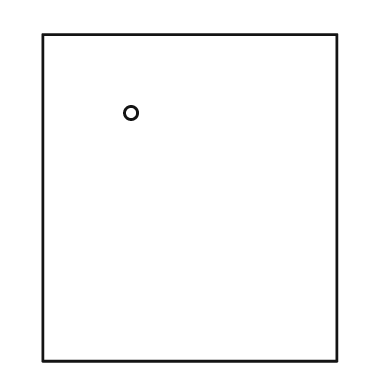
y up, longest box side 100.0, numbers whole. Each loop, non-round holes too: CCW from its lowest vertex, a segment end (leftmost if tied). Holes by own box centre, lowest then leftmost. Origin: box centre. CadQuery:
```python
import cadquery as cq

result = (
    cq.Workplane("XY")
    .moveTo(-45.0, -50.0)
    .lineTo(45.0, -50.0)
    .lineTo(45.0, 50.0)
    .lineTo(-45.0, 50.0)
    .close()
    .moveTo(-18.0, 26.0)
    .circle(2.0)
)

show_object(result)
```